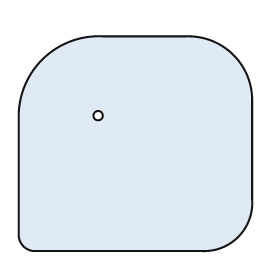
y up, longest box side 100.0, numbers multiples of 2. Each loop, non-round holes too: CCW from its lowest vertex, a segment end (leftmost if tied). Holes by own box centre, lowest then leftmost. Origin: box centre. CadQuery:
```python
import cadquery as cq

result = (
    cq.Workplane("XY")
    .moveTo(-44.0, -46.0)
    .lineTo(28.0, -46.0)
    .threePointArc((44.0, -40.0), (50.0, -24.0))
    .lineTo(50.0, 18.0)
    .threePointArc((42.0, 38.0), (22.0, 46.0))
    .lineTo(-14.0, 46.0)
    .threePointArc((-40.0, 36.0), (-50.0, 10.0))
    .lineTo(-50.0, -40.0)
    .threePointArc((-48.0, -44.0), (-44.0, -46.0))
    .close()
    .moveTo(-16.0, 12.0)
    .circle(2.0)
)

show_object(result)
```